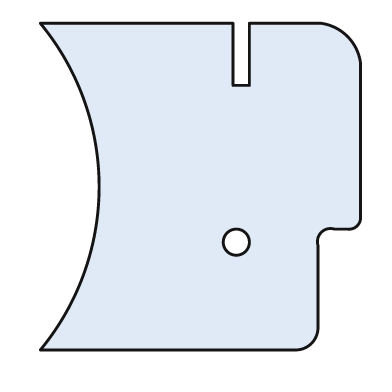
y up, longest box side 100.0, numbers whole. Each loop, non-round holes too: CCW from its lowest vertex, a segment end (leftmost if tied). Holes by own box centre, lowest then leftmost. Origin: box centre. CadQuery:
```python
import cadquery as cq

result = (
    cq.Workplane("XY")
    .moveTo(-49.0, -50.0)
    .lineTo(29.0, -50.0)
    .threePointArc((34.0, -48.0), (36.0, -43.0))
    .lineTo(36.0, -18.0)
    .threePointArc((37.0, -14.0), (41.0, -13.0))
    .lineTo(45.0, -13.0)
    .threePointArc((48.0, -12.0), (49.0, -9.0))
    .lineTo(49.0, 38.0)
    .threePointArc((45.0, 46.0), (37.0, 50.0))
    .lineTo(15.0, 50.0)
    .lineTo(15.0, 31.0)
    .lineTo(10.0, 31.0)
    .lineTo(10.0, 50.0)
    .lineTo(-49.0, 50.0)
    .threePointArc((-31.0, 0.0), (-49.0, -50.0))
    .close()
    .moveTo(11.0, -17.0)
    .circle(4.0)
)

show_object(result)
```